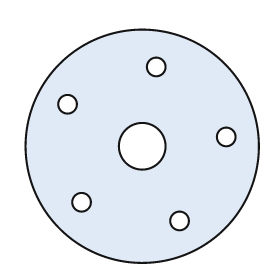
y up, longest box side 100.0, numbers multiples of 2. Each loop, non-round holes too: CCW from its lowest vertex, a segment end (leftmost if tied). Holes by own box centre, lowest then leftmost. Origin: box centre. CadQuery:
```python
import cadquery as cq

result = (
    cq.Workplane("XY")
    .moveTo(0.0, 0.0)
    .circle(50.0)
    .moveTo(16.0, -32.0)
    .circle(4.0)
    .moveTo(-26.0, -24.0)
    .circle(4.0)
    .moveTo(0.0, 0.0)
    .circle(10.0)
    .moveTo(36.0, 4.0)
    .circle(4.0)
    .moveTo(-32.0, 18.0)
    .circle(4.0)
    .moveTo(6.0, 34.0)
    .circle(4.0)
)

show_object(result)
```